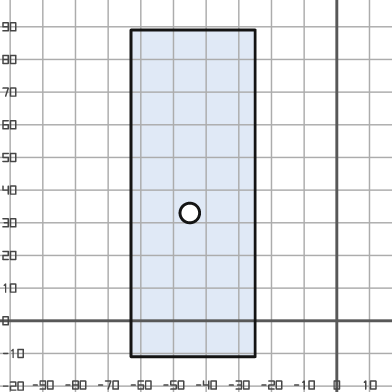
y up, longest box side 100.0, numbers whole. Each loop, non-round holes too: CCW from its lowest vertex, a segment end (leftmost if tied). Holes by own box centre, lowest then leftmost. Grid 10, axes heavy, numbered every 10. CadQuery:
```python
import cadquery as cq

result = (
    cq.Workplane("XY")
    .moveTo(-63.0, -11.0)
    .lineTo(-25.0, -11.0)
    .lineTo(-25.0, 89.0)
    .lineTo(-63.0, 89.0)
    .close()
    .moveTo(-45.0, 33.0)
    .circle(3.0)
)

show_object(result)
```